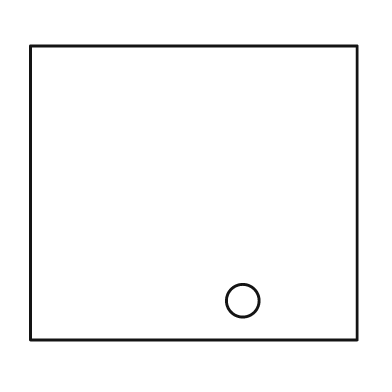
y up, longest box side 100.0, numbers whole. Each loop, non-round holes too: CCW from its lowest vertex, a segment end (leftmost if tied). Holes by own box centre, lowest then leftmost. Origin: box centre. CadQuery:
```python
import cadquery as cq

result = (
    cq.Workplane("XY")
    .moveTo(-50.0, -45.0)
    .lineTo(50.0, -45.0)
    .lineTo(50.0, 45.0)
    .lineTo(-50.0, 45.0)
    .close()
    .moveTo(15.0, -33.0)
    .circle(5.0)
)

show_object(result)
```